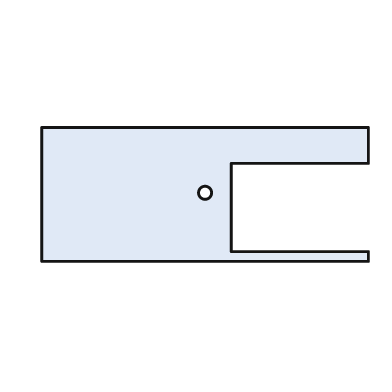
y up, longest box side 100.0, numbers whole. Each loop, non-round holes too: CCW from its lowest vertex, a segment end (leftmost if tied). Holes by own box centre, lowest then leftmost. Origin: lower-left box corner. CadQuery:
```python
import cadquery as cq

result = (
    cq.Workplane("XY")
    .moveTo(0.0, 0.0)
    .lineTo(100.0, 0.0)
    .lineTo(100.0, 3.0)
    .lineTo(58.0, 3.0)
    .lineTo(58.0, 30.0)
    .lineTo(100.0, 30.0)
    .lineTo(100.0, 41.0)
    .lineTo(0.0, 41.0)
    .close()
    .moveTo(50.0, 21.0)
    .circle(2.0)
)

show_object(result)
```